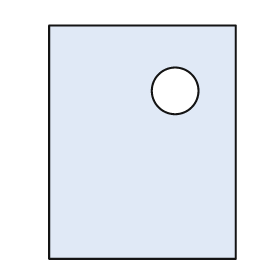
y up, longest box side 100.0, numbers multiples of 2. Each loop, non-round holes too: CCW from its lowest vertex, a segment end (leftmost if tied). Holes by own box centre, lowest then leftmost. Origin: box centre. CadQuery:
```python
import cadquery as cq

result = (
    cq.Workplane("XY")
    .moveTo(-40.0, -50.0)
    .lineTo(40.0, -50.0)
    .lineTo(40.0, 50.0)
    .lineTo(-40.0, 50.0)
    .close()
    .moveTo(14.0, 22.0)
    .circle(10.0)
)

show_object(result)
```